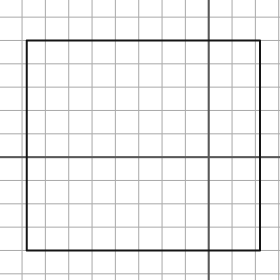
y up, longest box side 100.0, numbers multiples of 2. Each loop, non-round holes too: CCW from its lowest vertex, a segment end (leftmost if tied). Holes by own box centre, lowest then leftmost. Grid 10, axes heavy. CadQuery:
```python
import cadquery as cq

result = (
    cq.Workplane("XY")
    .moveTo(-78.0, -40.0)
    .lineTo(22.0, -40.0)
    .lineTo(22.0, 50.0)
    .lineTo(-78.0, 50.0)
    .close()
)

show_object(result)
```